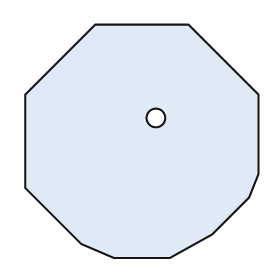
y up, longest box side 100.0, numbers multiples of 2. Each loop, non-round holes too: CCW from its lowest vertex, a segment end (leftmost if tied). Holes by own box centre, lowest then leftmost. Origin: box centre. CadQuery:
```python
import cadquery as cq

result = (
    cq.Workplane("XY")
    .moveTo(-12.0, -50.0)
    .lineTo(12.0, -50.0)
    .lineTo(30.0, -40.0)
    .lineTo(46.0, -24.0)
    .lineTo(50.0, -14.0)
    .lineTo(50.0, 20.0)
    .lineTo(20.0, 50.0)
    .lineTo(-20.0, 50.0)
    .lineTo(-50.0, 20.0)
    .lineTo(-50.0, -20.0)
    .lineTo(-26.0, -44.0)
    .close()
    .moveTo(6.0, 10.0)
    .circle(4.0)
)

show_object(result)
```